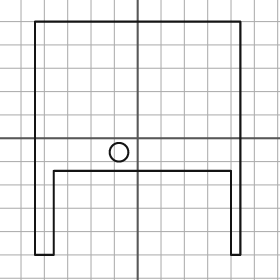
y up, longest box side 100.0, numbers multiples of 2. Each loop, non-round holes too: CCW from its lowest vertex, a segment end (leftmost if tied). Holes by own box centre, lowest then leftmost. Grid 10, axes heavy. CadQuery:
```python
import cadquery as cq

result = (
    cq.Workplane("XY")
    .moveTo(-44.0, -50.0)
    .lineTo(-36.0, -50.0)
    .lineTo(-36.0, -14.0)
    .lineTo(40.0, -14.0)
    .lineTo(40.0, -50.0)
    .lineTo(44.0, -50.0)
    .lineTo(44.0, 50.0)
    .lineTo(-44.0, 50.0)
    .close()
    .moveTo(-8.0, -6.0)
    .circle(4.0)
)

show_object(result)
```